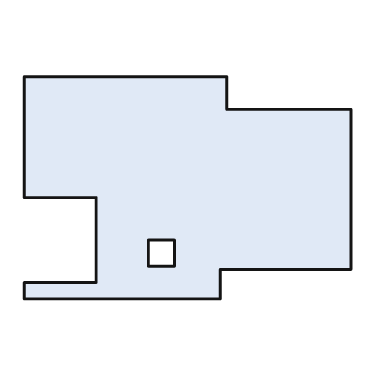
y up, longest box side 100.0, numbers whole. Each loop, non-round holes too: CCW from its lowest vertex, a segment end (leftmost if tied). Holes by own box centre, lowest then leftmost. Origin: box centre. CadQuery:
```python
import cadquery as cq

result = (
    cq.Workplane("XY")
    .moveTo(-50.0, -34.0)
    .lineTo(10.0, -34.0)
    .lineTo(10.0, -25.0)
    .lineTo(50.0, -25.0)
    .lineTo(50.0, 24.0)
    .lineTo(12.0, 24.0)
    .lineTo(12.0, 34.0)
    .lineTo(-50.0, 34.0)
    .lineTo(-50.0, -3.0)
    .lineTo(-28.0, -3.0)
    .lineTo(-28.0, -29.0)
    .lineTo(-50.0, -29.0)
    .close()
    .moveTo(-12.0, -24.0)
    .lineTo(-4.0, -24.0)
    .lineTo(-4.0, -16.0)
    .lineTo(-12.0, -16.0)
    .close()
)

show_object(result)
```